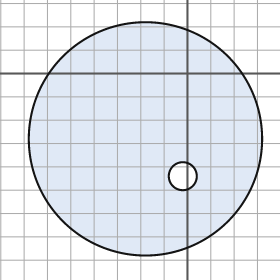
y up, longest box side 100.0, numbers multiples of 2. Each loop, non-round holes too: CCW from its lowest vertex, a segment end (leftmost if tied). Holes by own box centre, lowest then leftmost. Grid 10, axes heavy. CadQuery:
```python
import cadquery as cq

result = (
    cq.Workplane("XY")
    .moveTo(-18.0, -28.0)
    .circle(50.0)
    .moveTo(-2.0, -44.0)
    .circle(6.0)
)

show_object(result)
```